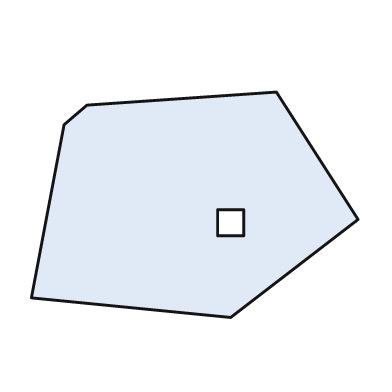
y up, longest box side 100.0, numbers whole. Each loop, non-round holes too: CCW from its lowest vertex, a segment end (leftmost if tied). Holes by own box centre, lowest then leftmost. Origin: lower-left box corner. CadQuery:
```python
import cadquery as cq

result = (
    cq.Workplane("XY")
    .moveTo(61.0, 0.0)
    .lineTo(100.0, 30.0)
    .lineTo(75.0, 69.0)
    .lineTo(17.0, 65.0)
    .lineTo(10.0, 59.0)
    .lineTo(0.0, 6.0)
    .close()
    .moveTo(57.0, 25.0)
    .lineTo(65.0, 25.0)
    .lineTo(65.0, 33.0)
    .lineTo(57.0, 33.0)
    .close()
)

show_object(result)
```